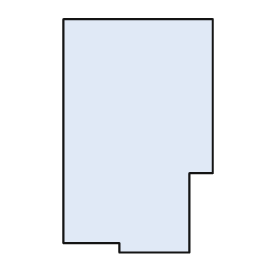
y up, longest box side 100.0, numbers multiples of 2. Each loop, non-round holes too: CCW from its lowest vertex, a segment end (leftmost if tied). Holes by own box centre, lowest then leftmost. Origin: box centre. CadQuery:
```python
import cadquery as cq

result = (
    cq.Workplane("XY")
    .moveTo(-8.0, -50.0)
    .lineTo(22.0, -50.0)
    .lineTo(22.0, -16.0)
    .lineTo(32.0, -16.0)
    .lineTo(32.0, 50.0)
    .lineTo(-32.0, 50.0)
    .lineTo(-32.0, -46.0)
    .lineTo(-8.0, -46.0)
    .close()
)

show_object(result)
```